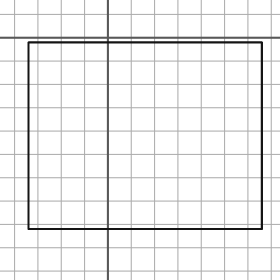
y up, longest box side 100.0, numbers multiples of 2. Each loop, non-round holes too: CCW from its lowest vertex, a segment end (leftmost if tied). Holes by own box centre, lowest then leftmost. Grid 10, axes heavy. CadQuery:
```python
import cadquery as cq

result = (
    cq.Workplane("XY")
    .moveTo(-34.0, -82.0)
    .lineTo(66.0, -82.0)
    .lineTo(66.0, -2.0)
    .lineTo(-34.0, -2.0)
    .close()
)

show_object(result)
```